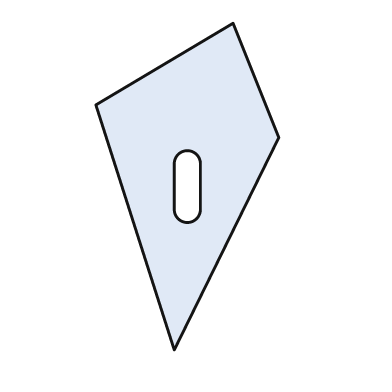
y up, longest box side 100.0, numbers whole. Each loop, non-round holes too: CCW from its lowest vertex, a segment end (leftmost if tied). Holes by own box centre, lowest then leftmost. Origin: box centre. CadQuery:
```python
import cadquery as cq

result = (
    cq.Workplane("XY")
    .moveTo(-4.0, -50.0)
    .lineTo(28.0, 15.0)
    .lineTo(14.0, 50.0)
    .lineTo(-28.0, 25.0)
    .close()
    .moveTo(-4.0, -7.0)
    .threePointArc((0.0, -11.0), (4.0, -7.0))
    .lineTo(4.0, 7.0)
    .threePointArc((0.0, 11.0), (-4.0, 7.0))
    .close()
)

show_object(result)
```